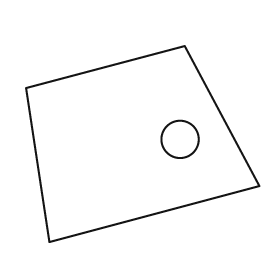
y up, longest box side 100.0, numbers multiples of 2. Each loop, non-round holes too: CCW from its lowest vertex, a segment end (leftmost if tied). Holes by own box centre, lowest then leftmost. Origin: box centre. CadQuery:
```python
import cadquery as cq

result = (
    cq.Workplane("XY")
    .moveTo(-40.0, -42.0)
    .lineTo(50.0, -18.0)
    .lineTo(18.0, 42.0)
    .lineTo(-50.0, 24.0)
    .close()
    .moveTo(16.0, 2.0)
    .circle(8.0)
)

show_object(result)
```